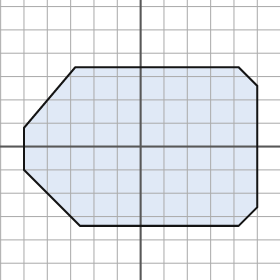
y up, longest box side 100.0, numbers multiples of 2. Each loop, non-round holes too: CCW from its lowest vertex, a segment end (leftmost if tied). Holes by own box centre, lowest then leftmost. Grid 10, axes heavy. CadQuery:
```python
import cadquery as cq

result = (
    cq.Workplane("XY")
    .moveTo(-26.0, -34.0)
    .lineTo(42.0, -34.0)
    .lineTo(50.0, -26.0)
    .lineTo(50.0, 26.0)
    .lineTo(42.0, 34.0)
    .lineTo(-28.0, 34.0)
    .lineTo(-50.0, 8.0)
    .lineTo(-50.0, -10.0)
    .close()
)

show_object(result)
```